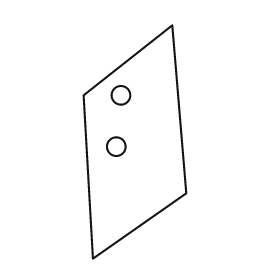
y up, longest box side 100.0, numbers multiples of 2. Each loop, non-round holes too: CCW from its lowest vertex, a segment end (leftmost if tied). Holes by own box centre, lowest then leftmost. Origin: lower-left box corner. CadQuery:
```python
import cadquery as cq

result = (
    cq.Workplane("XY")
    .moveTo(4.0, 0.0)
    .lineTo(44.0, 28.0)
    .lineTo(38.0, 100.0)
    .lineTo(0.0, 70.0)
    .close()
    .moveTo(14.0, 48.0)
    .circle(4.0)
    .moveTo(16.0, 70.0)
    .circle(4.0)
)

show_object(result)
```